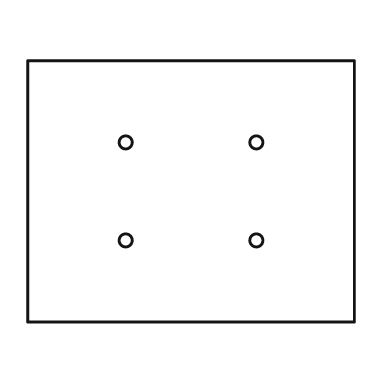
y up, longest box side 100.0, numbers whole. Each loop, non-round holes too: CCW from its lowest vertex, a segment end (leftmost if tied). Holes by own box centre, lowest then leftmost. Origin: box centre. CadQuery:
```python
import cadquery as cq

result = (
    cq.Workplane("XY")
    .moveTo(-50.0, -40.0)
    .lineTo(50.0, -40.0)
    .lineTo(50.0, 40.0)
    .lineTo(-50.0, 40.0)
    .close()
    .moveTo(-20.0, -15.0)
    .circle(2.0)
    .moveTo(20.0, -15.0)
    .circle(2.0)
    .moveTo(-20.0, 15.0)
    .circle(2.0)
    .moveTo(20.0, 15.0)
    .circle(2.0)
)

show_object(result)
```